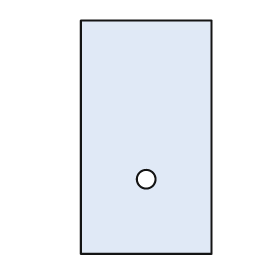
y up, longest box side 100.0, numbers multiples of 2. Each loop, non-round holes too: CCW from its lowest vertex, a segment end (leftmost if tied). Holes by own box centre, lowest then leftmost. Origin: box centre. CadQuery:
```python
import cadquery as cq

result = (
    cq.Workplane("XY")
    .moveTo(-28.0, -50.0)
    .lineTo(28.0, -50.0)
    .lineTo(28.0, 50.0)
    .lineTo(-28.0, 50.0)
    .close()
    .moveTo(0.0, -18.0)
    .circle(4.0)
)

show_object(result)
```